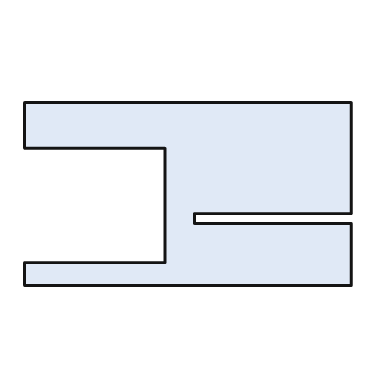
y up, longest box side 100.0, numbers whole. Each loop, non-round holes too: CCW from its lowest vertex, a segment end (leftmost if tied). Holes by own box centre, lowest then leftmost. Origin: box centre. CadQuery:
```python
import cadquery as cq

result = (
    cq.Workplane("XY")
    .moveTo(-50.0, -28.0)
    .lineTo(50.0, -28.0)
    .lineTo(50.0, -9.0)
    .lineTo(2.0, -9.0)
    .lineTo(2.0, -6.0)
    .lineTo(50.0, -6.0)
    .lineTo(50.0, 28.0)
    .lineTo(-50.0, 28.0)
    .lineTo(-50.0, 14.0)
    .lineTo(-7.0, 14.0)
    .lineTo(-7.0, -21.0)
    .lineTo(-50.0, -21.0)
    .close()
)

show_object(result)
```